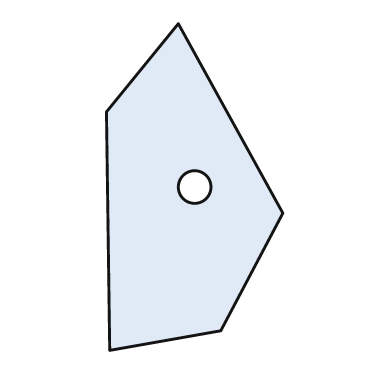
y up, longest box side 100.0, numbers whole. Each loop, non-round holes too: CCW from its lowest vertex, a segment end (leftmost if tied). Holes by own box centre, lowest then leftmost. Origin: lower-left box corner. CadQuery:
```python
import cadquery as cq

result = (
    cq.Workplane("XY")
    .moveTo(1.0, 0.0)
    .lineTo(35.0, 6.0)
    .lineTo(54.0, 42.0)
    .lineTo(22.0, 100.0)
    .lineTo(0.0, 73.0)
    .close()
    .moveTo(27.0, 50.0)
    .circle(5.0)
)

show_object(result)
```